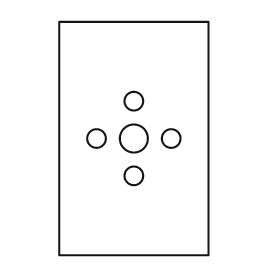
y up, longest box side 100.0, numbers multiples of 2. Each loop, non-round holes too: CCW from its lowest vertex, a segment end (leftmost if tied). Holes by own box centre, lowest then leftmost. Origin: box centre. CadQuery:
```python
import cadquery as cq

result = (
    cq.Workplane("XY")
    .moveTo(-32.0, -50.0)
    .lineTo(32.0, -50.0)
    .lineTo(32.0, 50.0)
    .lineTo(-32.0, 50.0)
    .close()
    .moveTo(0.0, -16.0)
    .circle(4.0)
    .moveTo(-16.0, 0.0)
    .circle(4.0)
    .moveTo(0.0, 0.0)
    .circle(6.0)
    .moveTo(16.0, 0.0)
    .circle(4.0)
    .moveTo(0.0, 16.0)
    .circle(4.0)
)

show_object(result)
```